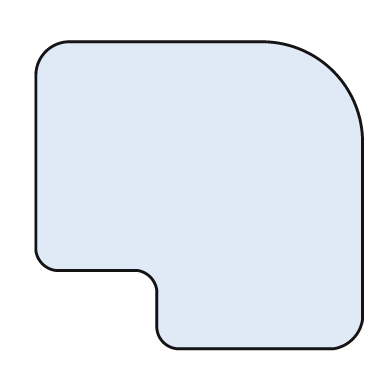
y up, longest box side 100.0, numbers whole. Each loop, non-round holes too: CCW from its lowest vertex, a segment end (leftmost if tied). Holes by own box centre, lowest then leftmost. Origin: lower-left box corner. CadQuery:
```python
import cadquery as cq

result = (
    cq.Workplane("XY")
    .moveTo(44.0, 0.0)
    .lineTo(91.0, 0.0)
    .threePointArc((97.0, 3.0), (100.0, 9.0))
    .lineTo(100.0, 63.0)
    .threePointArc((91.0, 85.0), (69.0, 94.0))
    .lineTo(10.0, 94.0)
    .threePointArc((3.0, 91.0), (0.0, 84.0))
    .lineTo(0.0, 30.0)
    .threePointArc((2.0, 26.0), (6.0, 24.0))
    .lineTo(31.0, 24.0)
    .threePointArc((35.0, 22.0), (37.0, 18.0))
    .lineTo(37.0, 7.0)
    .threePointArc((39.0, 2.0), (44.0, 0.0))
    .close()
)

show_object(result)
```